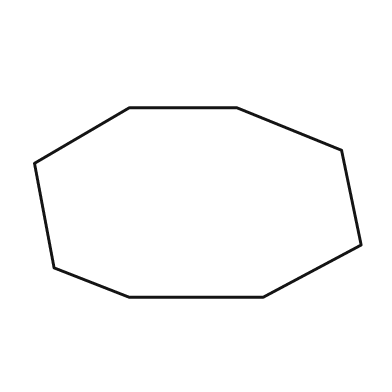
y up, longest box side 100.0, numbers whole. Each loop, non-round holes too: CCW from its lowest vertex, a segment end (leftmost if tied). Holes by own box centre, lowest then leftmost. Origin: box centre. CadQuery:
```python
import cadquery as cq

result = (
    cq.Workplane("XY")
    .moveTo(-21.0, -29.0)
    .lineTo(20.0, -29.0)
    .lineTo(50.0, -13.0)
    .lineTo(44.0, 16.0)
    .lineTo(12.0, 29.0)
    .lineTo(-21.0, 29.0)
    .lineTo(-50.0, 12.0)
    .lineTo(-44.0, -20.0)
    .close()
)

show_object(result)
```